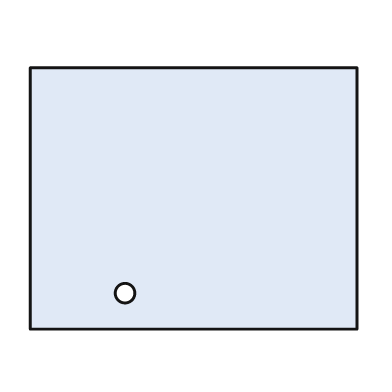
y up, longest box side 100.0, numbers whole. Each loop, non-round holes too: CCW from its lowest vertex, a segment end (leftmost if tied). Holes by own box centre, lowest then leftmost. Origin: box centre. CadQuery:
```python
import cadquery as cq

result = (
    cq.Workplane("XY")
    .moveTo(-50.0, -40.0)
    .lineTo(50.0, -40.0)
    .lineTo(50.0, 40.0)
    .lineTo(-50.0, 40.0)
    .close()
    .moveTo(-21.0, -29.0)
    .circle(3.0)
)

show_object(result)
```